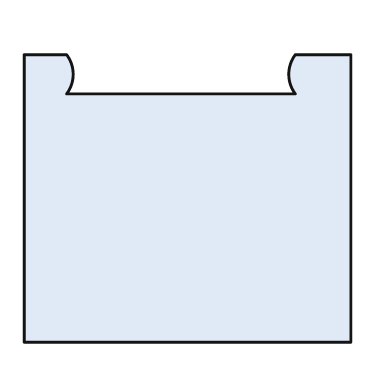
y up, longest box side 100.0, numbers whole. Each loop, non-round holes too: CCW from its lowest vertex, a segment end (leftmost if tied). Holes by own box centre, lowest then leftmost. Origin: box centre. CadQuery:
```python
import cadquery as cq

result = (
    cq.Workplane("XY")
    .moveTo(-50.0, -44.0)
    .lineTo(50.0, -44.0)
    .lineTo(50.0, 44.0)
    .lineTo(33.0, 44.0)
    .threePointArc((31.0, 38.0), (33.0, 32.0))
    .lineTo(-37.0, 32.0)
    .threePointArc((-35.0, 38.0), (-37.0, 44.0))
    .lineTo(-50.0, 44.0)
    .close()
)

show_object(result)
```